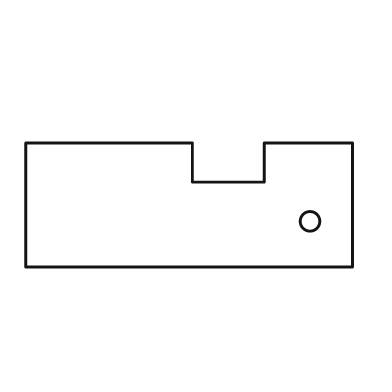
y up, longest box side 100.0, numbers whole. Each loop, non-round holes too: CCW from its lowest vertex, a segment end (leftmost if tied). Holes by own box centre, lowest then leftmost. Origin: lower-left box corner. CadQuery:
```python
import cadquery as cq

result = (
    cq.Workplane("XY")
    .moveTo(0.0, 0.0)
    .lineTo(100.0, 0.0)
    .lineTo(100.0, 38.0)
    .lineTo(73.0, 38.0)
    .lineTo(73.0, 26.0)
    .lineTo(51.0, 26.0)
    .lineTo(51.0, 38.0)
    .lineTo(0.0, 38.0)
    .close()
    .moveTo(87.0, 14.0)
    .circle(3.0)
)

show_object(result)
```